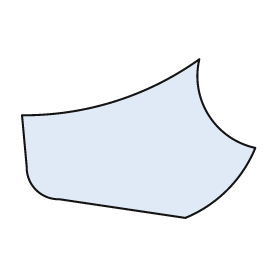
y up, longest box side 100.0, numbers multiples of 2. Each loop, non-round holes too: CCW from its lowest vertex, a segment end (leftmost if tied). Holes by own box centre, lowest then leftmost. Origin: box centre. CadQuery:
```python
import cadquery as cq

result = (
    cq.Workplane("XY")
    .moveTo(20.0, -34.0)
    .threePointArc((38.0, -22.0), (50.0, -4.0))
    .threePointArc((30.0, 10.0), (26.0, 34.0))
    .threePointArc((-10.0, 16.0), (-50.0, 10.0))
    .lineTo(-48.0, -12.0)
    .threePointArc((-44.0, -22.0), (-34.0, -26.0))
    .close()
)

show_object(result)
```